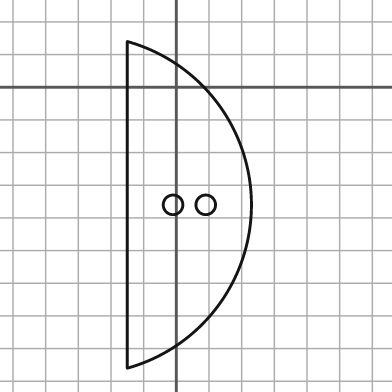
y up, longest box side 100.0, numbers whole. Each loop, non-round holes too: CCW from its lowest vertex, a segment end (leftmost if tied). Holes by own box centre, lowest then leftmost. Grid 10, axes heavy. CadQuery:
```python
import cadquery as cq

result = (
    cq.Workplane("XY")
    .moveTo(-15.0, -86.0)
    .threePointArc((23.0, -36.0), (-15.0, 14.0))
    .close()
    .moveTo(-1.0, -36.0)
    .circle(3.0)
    .moveTo(9.0, -36.0)
    .circle(3.0)
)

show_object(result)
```